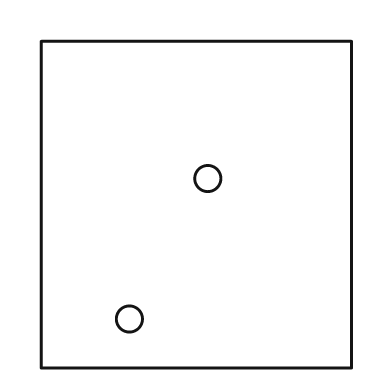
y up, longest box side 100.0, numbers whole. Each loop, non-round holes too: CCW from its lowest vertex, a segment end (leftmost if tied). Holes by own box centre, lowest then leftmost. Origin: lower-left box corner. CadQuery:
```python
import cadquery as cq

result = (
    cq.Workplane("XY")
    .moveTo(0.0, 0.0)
    .lineTo(95.0, 0.0)
    .lineTo(95.0, 100.0)
    .lineTo(0.0, 100.0)
    .close()
    .moveTo(27.0, 15.0)
    .circle(4.0)
    .moveTo(51.0, 58.0)
    .circle(4.0)
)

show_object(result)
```